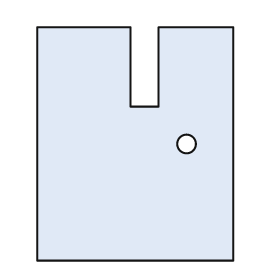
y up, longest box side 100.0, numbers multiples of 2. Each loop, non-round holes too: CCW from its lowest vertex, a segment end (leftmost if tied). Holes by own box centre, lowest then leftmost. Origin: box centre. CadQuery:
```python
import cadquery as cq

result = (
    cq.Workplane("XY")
    .moveTo(-42.0, -50.0)
    .lineTo(42.0, -50.0)
    .lineTo(42.0, 50.0)
    .lineTo(10.0, 50.0)
    .lineTo(10.0, 16.0)
    .lineTo(-2.0, 16.0)
    .lineTo(-2.0, 50.0)
    .lineTo(-42.0, 50.0)
    .close()
    .moveTo(22.0, 0.0)
    .circle(4.0)
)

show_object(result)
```